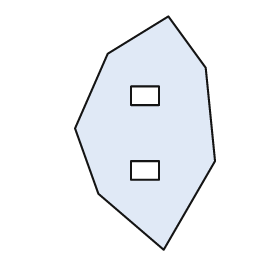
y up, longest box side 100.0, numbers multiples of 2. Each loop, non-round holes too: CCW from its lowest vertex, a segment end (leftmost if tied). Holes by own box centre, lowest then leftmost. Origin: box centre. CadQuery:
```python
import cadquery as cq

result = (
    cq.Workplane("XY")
    .moveTo(8.0, -50.0)
    .lineTo(30.0, -12.0)
    .lineTo(26.0, 28.0)
    .lineTo(10.0, 50.0)
    .lineTo(-16.0, 34.0)
    .lineTo(-30.0, 2.0)
    .lineTo(-20.0, -26.0)
    .close()
    .moveTo(-6.0, -20.0)
    .lineTo(6.0, -20.0)
    .lineTo(6.0, -12.0)
    .lineTo(-6.0, -12.0)
    .close()
    .moveTo(-6.0, 12.0)
    .lineTo(6.0, 12.0)
    .lineTo(6.0, 20.0)
    .lineTo(-6.0, 20.0)
    .close()
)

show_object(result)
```